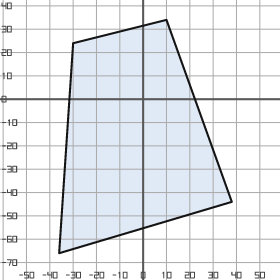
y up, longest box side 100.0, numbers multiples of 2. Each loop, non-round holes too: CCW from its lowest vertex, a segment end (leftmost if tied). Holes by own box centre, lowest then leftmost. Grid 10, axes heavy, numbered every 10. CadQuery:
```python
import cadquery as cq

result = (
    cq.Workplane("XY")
    .moveTo(-36.0, -66.0)
    .lineTo(38.0, -44.0)
    .lineTo(10.0, 34.0)
    .lineTo(-30.0, 24.0)
    .close()
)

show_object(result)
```